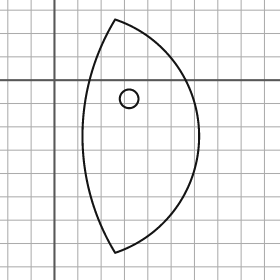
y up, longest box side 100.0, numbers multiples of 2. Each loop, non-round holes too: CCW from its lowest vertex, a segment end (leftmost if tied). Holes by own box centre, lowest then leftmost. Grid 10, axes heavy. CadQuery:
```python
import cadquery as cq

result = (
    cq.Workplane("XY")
    .moveTo(26.0, -74.0)
    .threePointArc((62.0, -24.0), (26.0, 26.0))
    .threePointArc((12.0, -24.0), (26.0, -74.0))
    .close()
    .moveTo(32.0, -8.0)
    .circle(4.0)
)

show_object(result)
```